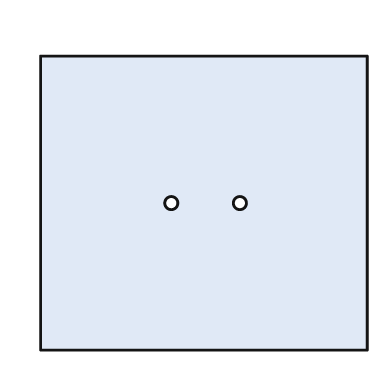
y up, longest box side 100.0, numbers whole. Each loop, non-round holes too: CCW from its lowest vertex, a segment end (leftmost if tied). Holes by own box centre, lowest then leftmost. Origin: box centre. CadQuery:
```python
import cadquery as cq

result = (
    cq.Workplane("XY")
    .moveTo(-50.0, -45.0)
    .lineTo(50.0, -45.0)
    .lineTo(50.0, 45.0)
    .lineTo(-50.0, 45.0)
    .close()
    .moveTo(-10.0, 0.0)
    .circle(2.0)
    .moveTo(11.0, 0.0)
    .circle(2.0)
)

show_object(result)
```